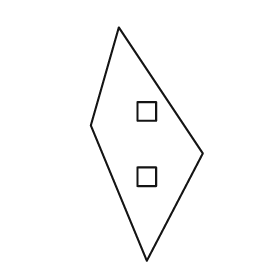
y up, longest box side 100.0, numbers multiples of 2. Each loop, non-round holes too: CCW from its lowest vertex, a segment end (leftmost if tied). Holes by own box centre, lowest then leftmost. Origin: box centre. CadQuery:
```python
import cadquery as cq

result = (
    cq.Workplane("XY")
    .moveTo(0.0, -50.0)
    .lineTo(24.0, -4.0)
    .lineTo(-12.0, 50.0)
    .lineTo(-24.0, 8.0)
    .close()
    .moveTo(-4.0, -18.0)
    .lineTo(4.0, -18.0)
    .lineTo(4.0, -10.0)
    .lineTo(-4.0, -10.0)
    .close()
    .moveTo(-4.0, 10.0)
    .lineTo(4.0, 10.0)
    .lineTo(4.0, 18.0)
    .lineTo(-4.0, 18.0)
    .close()
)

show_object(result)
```